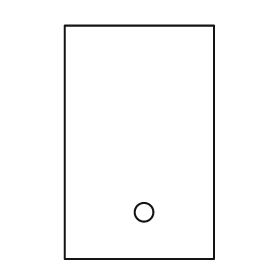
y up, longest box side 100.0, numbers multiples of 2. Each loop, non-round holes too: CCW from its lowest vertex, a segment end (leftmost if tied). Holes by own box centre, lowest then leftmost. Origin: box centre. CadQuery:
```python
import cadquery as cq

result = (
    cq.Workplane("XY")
    .moveTo(-32.0, -50.0)
    .lineTo(32.0, -50.0)
    .lineTo(32.0, 50.0)
    .lineTo(-32.0, 50.0)
    .close()
    .moveTo(2.0, -30.0)
    .circle(4.0)
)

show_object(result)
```